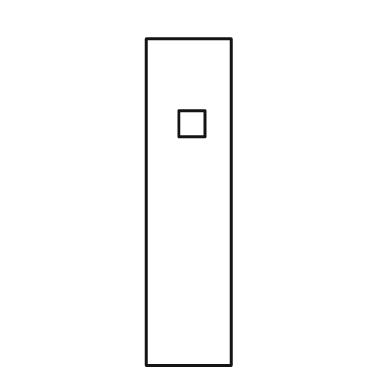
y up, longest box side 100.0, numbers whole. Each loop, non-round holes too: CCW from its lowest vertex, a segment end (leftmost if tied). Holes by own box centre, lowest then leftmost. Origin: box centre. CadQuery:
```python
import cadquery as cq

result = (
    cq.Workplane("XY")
    .moveTo(-13.0, -50.0)
    .lineTo(13.0, -50.0)
    .lineTo(13.0, 50.0)
    .lineTo(-13.0, 50.0)
    .close()
    .moveTo(-3.0, 20.0)
    .lineTo(5.0, 20.0)
    .lineTo(5.0, 28.0)
    .lineTo(-3.0, 28.0)
    .close()
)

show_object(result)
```